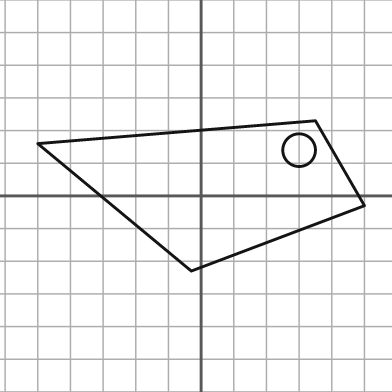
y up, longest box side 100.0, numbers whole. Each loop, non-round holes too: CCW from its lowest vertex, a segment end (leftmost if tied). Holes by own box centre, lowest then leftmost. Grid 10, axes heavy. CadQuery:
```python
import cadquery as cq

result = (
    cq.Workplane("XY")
    .moveTo(-3.0, -23.0)
    .lineTo(50.0, -3.0)
    .lineTo(35.0, 23.0)
    .lineTo(-50.0, 16.0)
    .close()
    .moveTo(30.0, 14.0)
    .circle(5.0)
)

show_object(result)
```